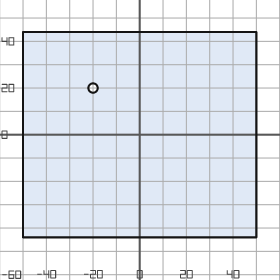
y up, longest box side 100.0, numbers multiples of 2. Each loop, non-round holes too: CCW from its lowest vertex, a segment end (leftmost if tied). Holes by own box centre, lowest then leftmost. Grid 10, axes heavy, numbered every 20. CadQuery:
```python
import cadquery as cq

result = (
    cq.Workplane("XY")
    .moveTo(-50.0, -44.0)
    .lineTo(50.0, -44.0)
    .lineTo(50.0, 44.0)
    .lineTo(-50.0, 44.0)
    .close()
    .moveTo(-20.0, 20.0)
    .circle(2.0)
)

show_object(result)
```